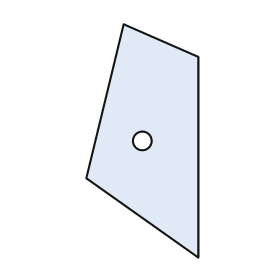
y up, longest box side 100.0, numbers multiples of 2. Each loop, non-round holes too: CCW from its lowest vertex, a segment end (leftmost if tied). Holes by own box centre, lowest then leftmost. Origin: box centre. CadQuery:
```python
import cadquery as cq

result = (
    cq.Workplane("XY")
    .moveTo(24.0, -50.0)
    .lineTo(24.0, 36.0)
    .lineTo(-8.0, 50.0)
    .lineTo(-24.0, -16.0)
    .close()
    .moveTo(0.0, 0.0)
    .circle(4.0)
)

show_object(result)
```